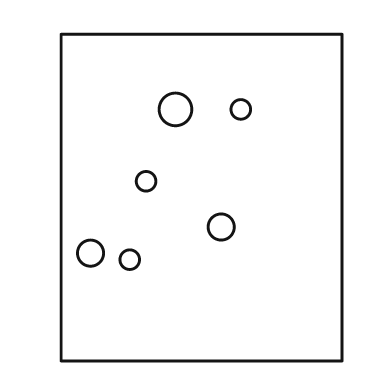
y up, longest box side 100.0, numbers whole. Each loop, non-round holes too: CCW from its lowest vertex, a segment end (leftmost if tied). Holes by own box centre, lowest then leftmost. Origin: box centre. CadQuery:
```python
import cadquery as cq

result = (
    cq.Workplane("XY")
    .moveTo(-43.0, -50.0)
    .lineTo(43.0, -50.0)
    .lineTo(43.0, 50.0)
    .lineTo(-43.0, 50.0)
    .close()
    .moveTo(-22.0, -19.0)
    .circle(3.0)
    .moveTo(-34.0, -17.0)
    .circle(4.0)
    .moveTo(6.0, -9.0)
    .circle(4.0)
    .moveTo(-17.0, 5.0)
    .circle(3.0)
    .moveTo(-8.0, 27.0)
    .circle(5.0)
    .moveTo(12.0, 27.0)
    .circle(3.0)
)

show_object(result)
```